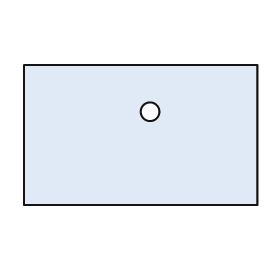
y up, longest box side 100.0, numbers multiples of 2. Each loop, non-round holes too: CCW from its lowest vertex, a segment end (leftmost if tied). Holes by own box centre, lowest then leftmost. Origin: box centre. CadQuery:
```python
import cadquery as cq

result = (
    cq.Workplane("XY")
    .moveTo(-50.0, -30.0)
    .lineTo(50.0, -30.0)
    .lineTo(50.0, 30.0)
    .lineTo(-50.0, 30.0)
    .close()
    .moveTo(4.0, 10.0)
    .circle(4.0)
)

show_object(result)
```